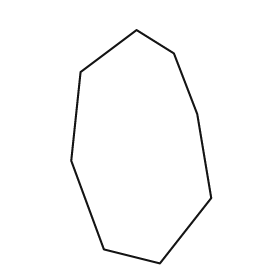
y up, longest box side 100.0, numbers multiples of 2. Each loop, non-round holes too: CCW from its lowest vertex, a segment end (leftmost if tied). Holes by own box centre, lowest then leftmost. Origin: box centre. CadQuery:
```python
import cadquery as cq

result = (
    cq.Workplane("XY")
    .moveTo(8.0, -50.0)
    .lineTo(30.0, -22.0)
    .lineTo(24.0, 14.0)
    .lineTo(14.0, 40.0)
    .lineTo(-2.0, 50.0)
    .lineTo(-26.0, 32.0)
    .lineTo(-30.0, -6.0)
    .lineTo(-16.0, -44.0)
    .close()
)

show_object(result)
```